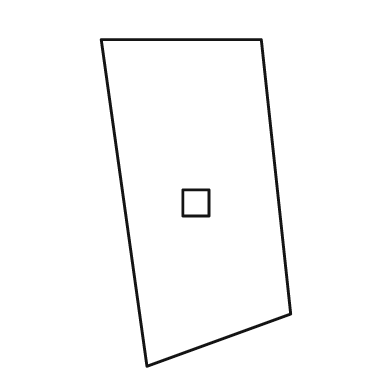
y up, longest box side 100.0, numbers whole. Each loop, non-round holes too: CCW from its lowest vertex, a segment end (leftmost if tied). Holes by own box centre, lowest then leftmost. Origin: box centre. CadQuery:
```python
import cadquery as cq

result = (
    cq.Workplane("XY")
    .moveTo(-15.0, -50.0)
    .lineTo(29.0, -34.0)
    .lineTo(20.0, 50.0)
    .lineTo(-29.0, 50.0)
    .close()
    .moveTo(-4.0, -4.0)
    .lineTo(4.0, -4.0)
    .lineTo(4.0, 4.0)
    .lineTo(-4.0, 4.0)
    .close()
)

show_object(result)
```